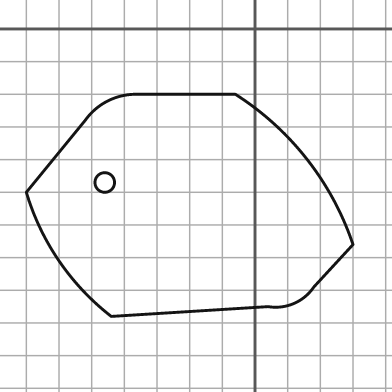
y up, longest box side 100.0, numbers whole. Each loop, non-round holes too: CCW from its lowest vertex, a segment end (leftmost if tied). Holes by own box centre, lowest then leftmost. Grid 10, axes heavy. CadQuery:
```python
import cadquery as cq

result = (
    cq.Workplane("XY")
    .moveTo(-44.0, -88.0)
    .lineTo(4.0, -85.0)
    .threePointArc((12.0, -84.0), (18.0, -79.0))
    .lineTo(30.0, -66.0)
    .threePointArc((16.0, -40.0), (-6.0, -20.0))
    .lineTo(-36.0, -20.0)
    .threePointArc((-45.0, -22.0), (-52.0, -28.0))
    .lineTo(-70.0, -50.0)
    .threePointArc((-60.0, -71.0), (-44.0, -88.0))
    .close()
    .moveTo(-46.0, -47.0)
    .circle(3.0)
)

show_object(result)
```